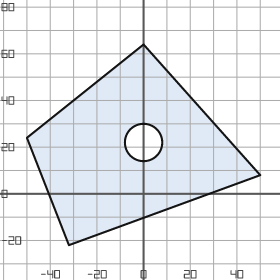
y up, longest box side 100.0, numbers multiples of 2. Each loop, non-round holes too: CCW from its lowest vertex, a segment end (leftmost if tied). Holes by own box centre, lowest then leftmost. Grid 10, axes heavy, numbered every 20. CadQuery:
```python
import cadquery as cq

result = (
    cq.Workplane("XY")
    .moveTo(-32.0, -22.0)
    .lineTo(50.0, 8.0)
    .lineTo(0.0, 64.0)
    .lineTo(-50.0, 24.0)
    .close()
    .moveTo(0.0, 22.0)
    .circle(8.0)
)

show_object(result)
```